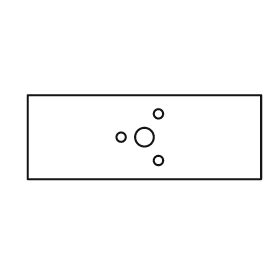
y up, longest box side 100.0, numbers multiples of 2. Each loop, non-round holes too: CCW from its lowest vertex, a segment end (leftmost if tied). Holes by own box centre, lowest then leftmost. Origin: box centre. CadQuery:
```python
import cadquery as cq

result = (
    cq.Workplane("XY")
    .moveTo(-50.0, -18.0)
    .lineTo(50.0, -18.0)
    .lineTo(50.0, 18.0)
    .lineTo(-50.0, 18.0)
    .close()
    .moveTo(6.0, -10.0)
    .circle(2.0)
    .moveTo(-10.0, 0.0)
    .circle(2.0)
    .moveTo(0.0, 0.0)
    .circle(4.0)
    .moveTo(6.0, 10.0)
    .circle(2.0)
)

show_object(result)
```